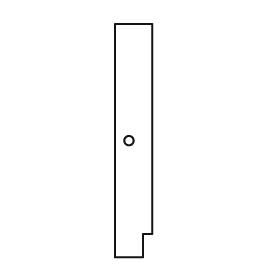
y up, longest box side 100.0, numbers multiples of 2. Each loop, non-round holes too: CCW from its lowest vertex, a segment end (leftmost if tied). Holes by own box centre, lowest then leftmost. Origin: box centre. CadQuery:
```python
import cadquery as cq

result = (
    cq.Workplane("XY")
    .moveTo(-8.0, -50.0)
    .lineTo(4.0, -50.0)
    .lineTo(4.0, -40.0)
    .lineTo(8.0, -40.0)
    .lineTo(8.0, 50.0)
    .lineTo(-8.0, 50.0)
    .close()
    .moveTo(-2.0, 0.0)
    .circle(2.0)
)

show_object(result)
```